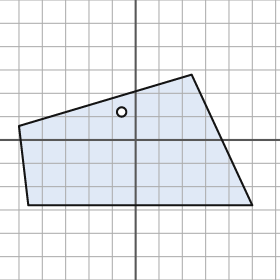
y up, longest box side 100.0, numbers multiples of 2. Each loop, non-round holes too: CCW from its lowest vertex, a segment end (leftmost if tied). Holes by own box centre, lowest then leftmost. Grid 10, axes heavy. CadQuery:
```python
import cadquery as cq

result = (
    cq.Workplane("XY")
    .moveTo(-46.0, -28.0)
    .lineTo(50.0, -28.0)
    .lineTo(24.0, 28.0)
    .lineTo(-50.0, 6.0)
    .close()
    .moveTo(-6.0, 12.0)
    .circle(2.0)
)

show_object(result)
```